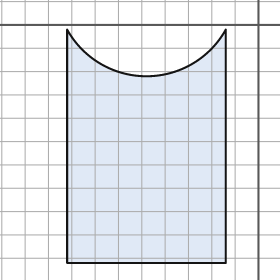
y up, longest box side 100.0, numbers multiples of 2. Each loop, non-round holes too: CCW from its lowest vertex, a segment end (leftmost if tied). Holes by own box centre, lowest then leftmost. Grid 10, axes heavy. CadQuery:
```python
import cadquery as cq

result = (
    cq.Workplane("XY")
    .moveTo(-82.0, -102.0)
    .lineTo(-14.0, -102.0)
    .lineTo(-14.0, -2.0)
    .threePointArc((-48.0, -22.0), (-82.0, -2.0))
    .close()
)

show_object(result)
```